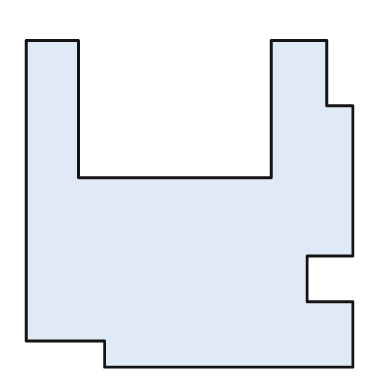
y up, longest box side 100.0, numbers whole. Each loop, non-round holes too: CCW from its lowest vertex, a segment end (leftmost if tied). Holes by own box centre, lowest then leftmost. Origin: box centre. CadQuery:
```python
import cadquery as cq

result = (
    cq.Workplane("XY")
    .moveTo(-26.0, -50.0)
    .lineTo(50.0, -50.0)
    .lineTo(50.0, -30.0)
    .lineTo(36.0, -30.0)
    .lineTo(36.0, -16.0)
    .lineTo(50.0, -16.0)
    .lineTo(50.0, 30.0)
    .lineTo(42.0, 30.0)
    .lineTo(42.0, 50.0)
    .lineTo(25.0, 50.0)
    .lineTo(25.0, 8.0)
    .lineTo(-34.0, 8.0)
    .lineTo(-34.0, 50.0)
    .lineTo(-50.0, 50.0)
    .lineTo(-50.0, -42.0)
    .lineTo(-26.0, -42.0)
    .close()
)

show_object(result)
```